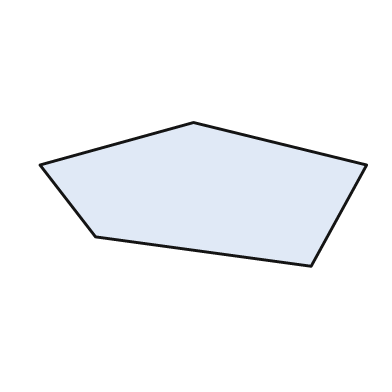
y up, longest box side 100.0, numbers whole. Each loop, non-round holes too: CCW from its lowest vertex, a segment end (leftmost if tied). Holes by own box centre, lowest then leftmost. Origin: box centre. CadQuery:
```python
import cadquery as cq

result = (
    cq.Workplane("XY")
    .moveTo(33.0, -22.0)
    .lineTo(50.0, 9.0)
    .lineTo(-3.0, 22.0)
    .lineTo(-50.0, 9.0)
    .lineTo(-33.0, -13.0)
    .close()
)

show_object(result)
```